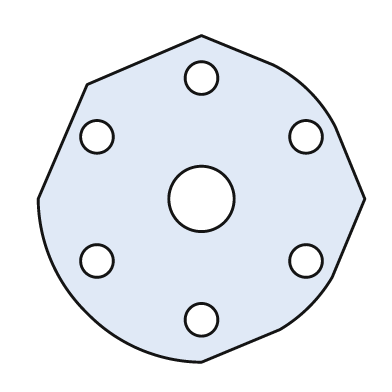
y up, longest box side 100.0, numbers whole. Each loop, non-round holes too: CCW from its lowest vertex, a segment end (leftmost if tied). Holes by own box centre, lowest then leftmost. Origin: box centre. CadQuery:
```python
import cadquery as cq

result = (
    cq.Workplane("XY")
    .moveTo(0.0, -50.0)
    .lineTo(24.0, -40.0)
    .threePointArc((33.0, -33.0), (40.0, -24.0))
    .lineTo(50.0, 0.0)
    .lineTo(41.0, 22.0)
    .threePointArc((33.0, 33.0), (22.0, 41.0))
    .lineTo(0.0, 50.0)
    .lineTo(-35.0, 35.0)
    .lineTo(-50.0, 0.0)
    .threePointArc((-46.0, -19.0), (-35.0, -35.0))
    .threePointArc((-19.0, -46.0), (0.0, -50.0))
    .close()
    .moveTo(0.0, -37.0)
    .circle(5.0)
    .moveTo(-32.0, -19.0)
    .circle(5.0)
    .moveTo(32.0, -19.0)
    .circle(5.0)
    .moveTo(0.0, 0.0)
    .circle(10.0)
    .moveTo(-32.0, 19.0)
    .circle(5.0)
    .moveTo(32.0, 19.0)
    .circle(5.0)
    .moveTo(0.0, 37.0)
    .circle(5.0)
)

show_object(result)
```